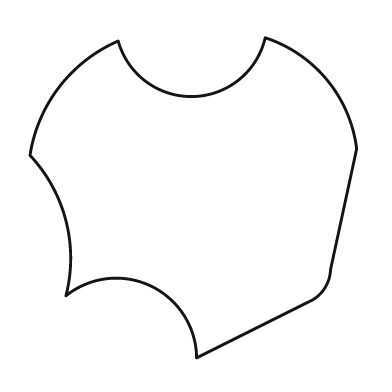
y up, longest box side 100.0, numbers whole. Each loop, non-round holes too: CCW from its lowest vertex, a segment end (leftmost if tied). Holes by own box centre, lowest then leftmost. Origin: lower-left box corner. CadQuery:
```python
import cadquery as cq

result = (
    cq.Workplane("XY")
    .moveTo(51.0, 0.0)
    .lineTo(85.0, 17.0)
    .threePointArc((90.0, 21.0), (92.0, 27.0))
    .lineTo(100.0, 64.0)
    .threePointArc((91.0, 85.0), (72.0, 98.0))
    .threePointArc((50.0, 80.0), (27.0, 97.0))
    .threePointArc((9.0, 83.0), (0.0, 62.0))
    .threePointArc((11.0, 42.0), (11.0, 19.0))
    .threePointArc((37.0, 22.0), (51.0, 0.0))
    .close()
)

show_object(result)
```